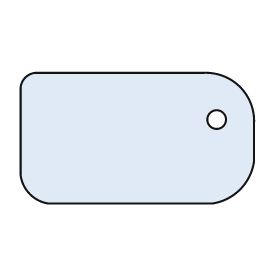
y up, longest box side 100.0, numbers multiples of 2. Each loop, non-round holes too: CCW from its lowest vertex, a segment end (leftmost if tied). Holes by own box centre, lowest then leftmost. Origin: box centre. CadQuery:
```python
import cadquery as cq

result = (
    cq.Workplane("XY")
    .moveTo(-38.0, -28.0)
    .lineTo(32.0, -28.0)
    .threePointArc((44.0, -22.0), (50.0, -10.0))
    .lineTo(50.0, 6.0)
    .threePointArc((44.0, 22.0), (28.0, 28.0))
    .lineTo(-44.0, 28.0)
    .threePointArc((-48.0, 26.0), (-50.0, 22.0))
    .lineTo(-50.0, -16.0)
    .threePointArc((-46.0, -24.0), (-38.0, -28.0))
    .close()
    .moveTo(34.0, 8.0)
    .circle(4.0)
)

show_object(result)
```